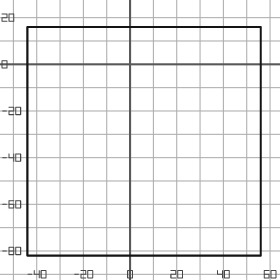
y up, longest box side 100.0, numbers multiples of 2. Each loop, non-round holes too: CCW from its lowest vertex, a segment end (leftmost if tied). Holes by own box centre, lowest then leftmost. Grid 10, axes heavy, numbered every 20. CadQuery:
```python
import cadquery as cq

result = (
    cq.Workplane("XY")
    .moveTo(-44.0, -82.0)
    .lineTo(56.0, -82.0)
    .lineTo(56.0, 16.0)
    .lineTo(-44.0, 16.0)
    .close()
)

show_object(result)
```